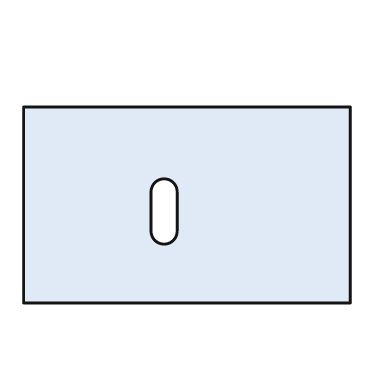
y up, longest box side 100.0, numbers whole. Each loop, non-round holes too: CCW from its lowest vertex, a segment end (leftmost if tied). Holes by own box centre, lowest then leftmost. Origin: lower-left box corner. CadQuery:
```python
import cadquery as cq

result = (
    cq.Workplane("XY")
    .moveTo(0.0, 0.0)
    .lineTo(100.0, 0.0)
    .lineTo(100.0, 60.0)
    .lineTo(0.0, 60.0)
    .close()
    .moveTo(39.0, 22.0)
    .threePointArc((43.0, 18.0), (47.0, 22.0))
    .lineTo(47.0, 34.0)
    .threePointArc((43.0, 38.0), (39.0, 34.0))
    .close()
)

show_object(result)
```